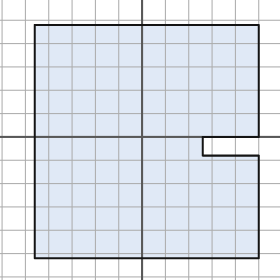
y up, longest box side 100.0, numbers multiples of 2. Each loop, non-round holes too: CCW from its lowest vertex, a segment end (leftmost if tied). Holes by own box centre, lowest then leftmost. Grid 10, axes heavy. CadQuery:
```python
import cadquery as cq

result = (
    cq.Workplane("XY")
    .moveTo(-46.0, -52.0)
    .lineTo(50.0, -52.0)
    .lineTo(50.0, -8.0)
    .lineTo(26.0, -8.0)
    .lineTo(26.0, 0.0)
    .lineTo(50.0, 0.0)
    .lineTo(50.0, 48.0)
    .lineTo(-46.0, 48.0)
    .close()
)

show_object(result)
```